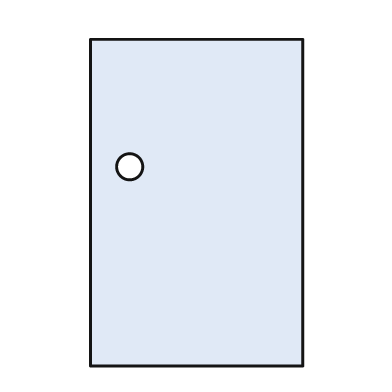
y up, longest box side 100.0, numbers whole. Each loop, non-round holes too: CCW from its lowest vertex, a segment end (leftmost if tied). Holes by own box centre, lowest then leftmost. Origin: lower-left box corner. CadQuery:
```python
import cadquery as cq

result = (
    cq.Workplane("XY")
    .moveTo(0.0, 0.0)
    .lineTo(65.0, 0.0)
    .lineTo(65.0, 100.0)
    .lineTo(0.0, 100.0)
    .close()
    .moveTo(12.0, 61.0)
    .circle(4.0)
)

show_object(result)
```